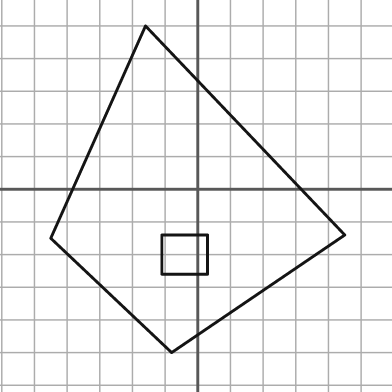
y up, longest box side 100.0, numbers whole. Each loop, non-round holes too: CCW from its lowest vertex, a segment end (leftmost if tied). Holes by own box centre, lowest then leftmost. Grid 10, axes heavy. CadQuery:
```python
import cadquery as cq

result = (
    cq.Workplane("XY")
    .moveTo(-8.0, -50.0)
    .lineTo(45.0, -14.0)
    .lineTo(-16.0, 50.0)
    .lineTo(-45.0, -15.0)
    .close()
    .moveTo(-11.0, -26.0)
    .lineTo(3.0, -26.0)
    .lineTo(3.0, -14.0)
    .lineTo(-11.0, -14.0)
    .close()
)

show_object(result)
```